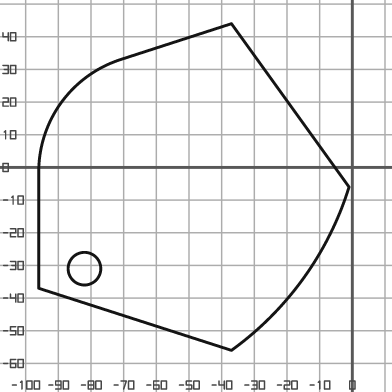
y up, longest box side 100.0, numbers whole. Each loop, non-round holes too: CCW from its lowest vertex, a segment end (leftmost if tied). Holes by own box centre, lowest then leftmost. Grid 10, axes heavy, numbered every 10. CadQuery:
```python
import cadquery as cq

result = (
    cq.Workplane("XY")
    .moveTo(-37.0, -56.0)
    .threePointArc((-15.0, -34.0), (-1.0, -6.0))
    .lineTo(-37.0, 44.0)
    .lineTo(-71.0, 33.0)
    .threePointArc((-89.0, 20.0), (-96.0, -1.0))
    .lineTo(-96.0, -37.0)
    .close()
    .moveTo(-82.0, -31.0)
    .circle(5.0)
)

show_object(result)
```